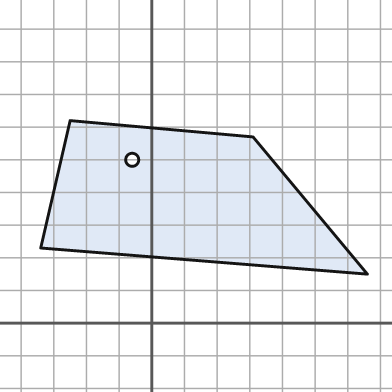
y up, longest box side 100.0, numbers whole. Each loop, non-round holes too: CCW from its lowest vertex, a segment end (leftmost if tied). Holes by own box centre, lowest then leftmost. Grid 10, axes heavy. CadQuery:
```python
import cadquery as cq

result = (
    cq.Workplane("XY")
    .moveTo(66.0, 15.0)
    .lineTo(31.0, 57.0)
    .lineTo(-25.0, 62.0)
    .lineTo(-34.0, 23.0)
    .close()
    .moveTo(-6.0, 50.0)
    .circle(2.0)
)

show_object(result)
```